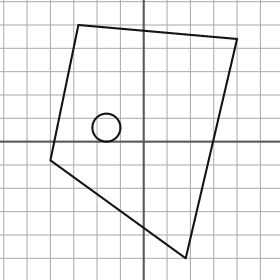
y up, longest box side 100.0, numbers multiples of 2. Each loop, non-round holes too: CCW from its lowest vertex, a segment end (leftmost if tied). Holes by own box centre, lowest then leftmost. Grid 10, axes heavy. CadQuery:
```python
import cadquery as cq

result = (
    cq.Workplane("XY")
    .moveTo(18.0, -50.0)
    .lineTo(40.0, 44.0)
    .lineTo(-28.0, 50.0)
    .lineTo(-40.0, -8.0)
    .close()
    .moveTo(-16.0, 6.0)
    .circle(6.0)
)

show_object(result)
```